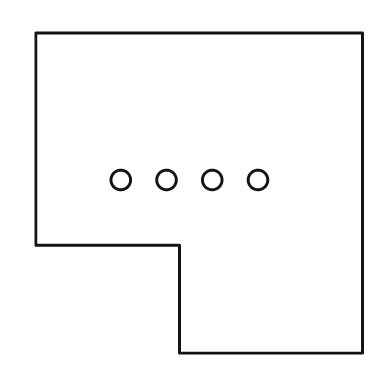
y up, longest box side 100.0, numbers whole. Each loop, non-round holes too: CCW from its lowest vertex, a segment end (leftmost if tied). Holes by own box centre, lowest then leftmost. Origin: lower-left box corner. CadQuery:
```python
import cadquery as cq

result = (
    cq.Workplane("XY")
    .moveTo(44.0, 0.0)
    .lineTo(100.0, 0.0)
    .lineTo(100.0, 98.0)
    .lineTo(0.0, 98.0)
    .lineTo(0.0, 33.0)
    .lineTo(44.0, 33.0)
    .close()
    .moveTo(26.0, 53.0)
    .circle(3.0)
    .moveTo(40.0, 53.0)
    .circle(3.0)
    .moveTo(54.0, 53.0)
    .circle(3.0)
    .moveTo(68.0, 53.0)
    .circle(3.0)
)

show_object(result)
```